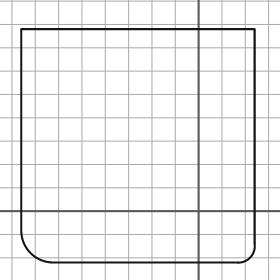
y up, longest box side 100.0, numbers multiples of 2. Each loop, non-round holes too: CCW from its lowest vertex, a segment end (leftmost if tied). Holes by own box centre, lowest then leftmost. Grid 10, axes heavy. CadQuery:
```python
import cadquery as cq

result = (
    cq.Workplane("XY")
    .moveTo(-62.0, -22.0)
    .lineTo(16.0, -22.0)
    .threePointArc((22.0, -20.0), (24.0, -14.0))
    .lineTo(24.0, 78.0)
    .lineTo(-76.0, 78.0)
    .lineTo(-76.0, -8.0)
    .threePointArc((-72.0, -18.0), (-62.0, -22.0))
    .close()
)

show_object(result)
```